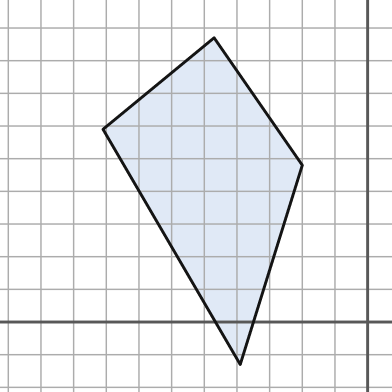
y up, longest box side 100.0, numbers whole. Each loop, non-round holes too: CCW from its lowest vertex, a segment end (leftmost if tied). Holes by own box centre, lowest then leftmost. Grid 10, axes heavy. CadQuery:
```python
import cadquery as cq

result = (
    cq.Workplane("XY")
    .moveTo(-39.0, -13.0)
    .lineTo(-20.0, 48.0)
    .lineTo(-47.0, 87.0)
    .lineTo(-81.0, 59.0)
    .close()
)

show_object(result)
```